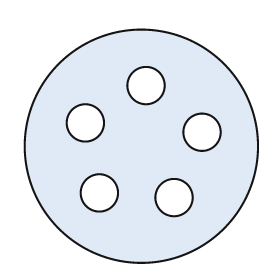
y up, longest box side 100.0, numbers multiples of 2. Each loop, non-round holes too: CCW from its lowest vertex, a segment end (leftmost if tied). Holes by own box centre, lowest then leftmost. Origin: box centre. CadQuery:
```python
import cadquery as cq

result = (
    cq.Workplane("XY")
    .moveTo(0.0, 0.0)
    .circle(50.0)
    .moveTo(14.0, -22.0)
    .circle(8.0)
    .moveTo(-18.0, -20.0)
    .circle(8.0)
    .moveTo(26.0, 6.0)
    .circle(8.0)
    .moveTo(-24.0, 10.0)
    .circle(8.0)
    .moveTo(2.0, 26.0)
    .circle(8.0)
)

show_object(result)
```